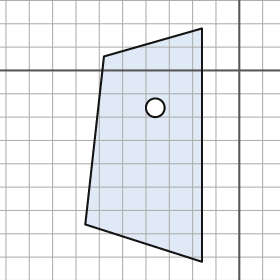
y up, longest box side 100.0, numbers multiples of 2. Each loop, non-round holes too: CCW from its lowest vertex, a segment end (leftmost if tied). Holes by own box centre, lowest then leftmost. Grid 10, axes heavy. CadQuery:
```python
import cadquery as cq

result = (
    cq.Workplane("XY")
    .moveTo(-16.0, -82.0)
    .lineTo(-16.0, 18.0)
    .lineTo(-58.0, 6.0)
    .lineTo(-66.0, -66.0)
    .close()
    .moveTo(-36.0, -16.0)
    .circle(4.0)
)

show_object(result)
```